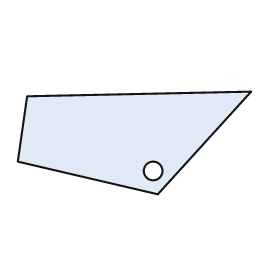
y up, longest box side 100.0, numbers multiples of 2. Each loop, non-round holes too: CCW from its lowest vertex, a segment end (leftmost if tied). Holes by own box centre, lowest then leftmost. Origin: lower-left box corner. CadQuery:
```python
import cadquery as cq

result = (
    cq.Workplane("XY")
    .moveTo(60.0, 0.0)
    .lineTo(100.0, 44.0)
    .lineTo(4.0, 42.0)
    .lineTo(0.0, 14.0)
    .close()
    .moveTo(58.0, 10.0)
    .circle(4.0)
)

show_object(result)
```